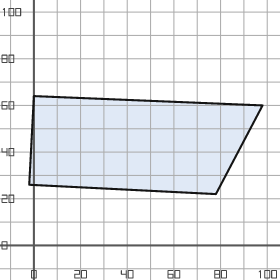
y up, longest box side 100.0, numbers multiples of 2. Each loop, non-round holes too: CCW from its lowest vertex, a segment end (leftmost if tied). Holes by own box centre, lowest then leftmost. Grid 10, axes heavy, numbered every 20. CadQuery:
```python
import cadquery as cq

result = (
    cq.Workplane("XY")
    .moveTo(78.0, 22.0)
    .lineTo(98.0, 60.0)
    .lineTo(0.0, 64.0)
    .lineTo(-2.0, 26.0)
    .close()
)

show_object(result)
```